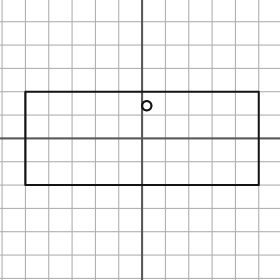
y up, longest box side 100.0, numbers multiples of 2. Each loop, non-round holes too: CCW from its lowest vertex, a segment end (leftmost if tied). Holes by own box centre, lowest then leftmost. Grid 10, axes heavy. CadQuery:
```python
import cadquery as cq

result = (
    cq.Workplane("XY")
    .moveTo(-50.0, -20.0)
    .lineTo(50.0, -20.0)
    .lineTo(50.0, 20.0)
    .lineTo(-50.0, 20.0)
    .close()
    .moveTo(2.0, 14.0)
    .circle(2.0)
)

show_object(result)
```